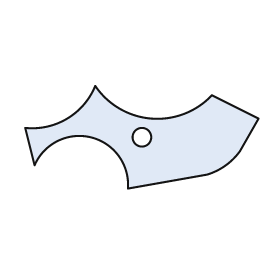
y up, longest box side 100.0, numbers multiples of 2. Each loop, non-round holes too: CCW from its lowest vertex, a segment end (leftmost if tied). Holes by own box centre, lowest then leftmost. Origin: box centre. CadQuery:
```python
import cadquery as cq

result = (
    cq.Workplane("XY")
    .moveTo(-6.0, -22.0)
    .lineTo(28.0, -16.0)
    .threePointArc((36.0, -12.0), (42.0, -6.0))
    .lineTo(50.0, 8.0)
    .lineTo(30.0, 18.0)
    .threePointArc((4.0, 8.0), (-20.0, 22.0))
    .threePointArc((-32.0, 8.0), (-50.0, 4.0))
    .lineTo(-46.0, -12.0)
    .threePointArc((-22.0, 0.0), (-6.0, -22.0))
    .close()
    .moveTo(0.0, 0.0)
    .circle(4.0)
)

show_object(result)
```